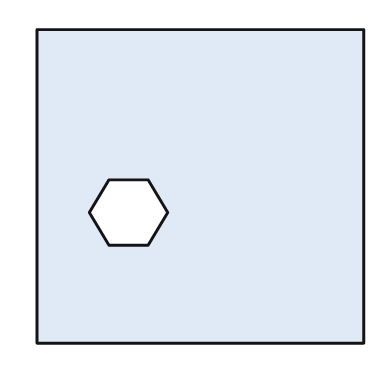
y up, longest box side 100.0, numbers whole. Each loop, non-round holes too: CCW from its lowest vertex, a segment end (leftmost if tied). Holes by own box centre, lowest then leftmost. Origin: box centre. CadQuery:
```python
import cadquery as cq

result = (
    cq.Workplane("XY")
    .moveTo(-50.0, -48.0)
    .lineTo(50.0, -48.0)
    .lineTo(50.0, 48.0)
    .lineTo(-50.0, 48.0)
    .close()
    .moveTo(-28.0, -18.0)
    .lineTo(-16.0, -18.0)
    .lineTo(-10.0, -8.0)
    .lineTo(-16.0, 2.0)
    .lineTo(-28.0, 2.0)
    .lineTo(-34.0, -8.0)
    .close()
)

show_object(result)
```